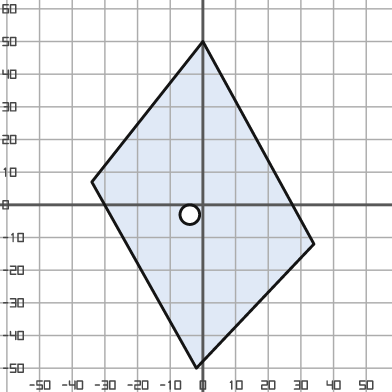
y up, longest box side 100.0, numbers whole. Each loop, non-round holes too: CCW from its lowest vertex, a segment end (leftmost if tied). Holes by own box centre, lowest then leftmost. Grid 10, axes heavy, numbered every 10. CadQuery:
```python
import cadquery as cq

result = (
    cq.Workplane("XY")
    .moveTo(-2.0, -50.0)
    .lineTo(34.0, -12.0)
    .lineTo(0.0, 50.0)
    .lineTo(-34.0, 7.0)
    .close()
    .moveTo(-4.0, -3.0)
    .circle(3.0)
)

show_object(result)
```